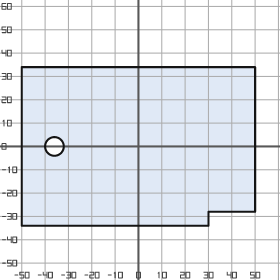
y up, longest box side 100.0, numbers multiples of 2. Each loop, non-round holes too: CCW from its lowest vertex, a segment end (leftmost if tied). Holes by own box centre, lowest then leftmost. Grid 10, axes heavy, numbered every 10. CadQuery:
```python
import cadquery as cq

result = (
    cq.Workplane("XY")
    .moveTo(-50.0, -34.0)
    .lineTo(30.0, -34.0)
    .lineTo(30.0, -28.0)
    .lineTo(50.0, -28.0)
    .lineTo(50.0, 34.0)
    .lineTo(-50.0, 34.0)
    .close()
    .moveTo(-36.0, 0.0)
    .circle(4.0)
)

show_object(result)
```